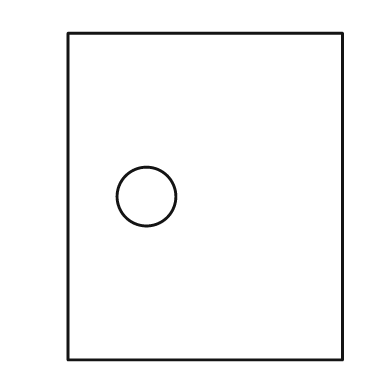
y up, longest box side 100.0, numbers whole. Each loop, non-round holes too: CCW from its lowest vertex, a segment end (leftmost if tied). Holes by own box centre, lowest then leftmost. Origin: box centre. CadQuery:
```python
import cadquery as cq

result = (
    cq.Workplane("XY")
    .moveTo(-42.0, -50.0)
    .lineTo(42.0, -50.0)
    .lineTo(42.0, 50.0)
    .lineTo(-42.0, 50.0)
    .close()
    .moveTo(-18.0, 0.0)
    .circle(9.0)
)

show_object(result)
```